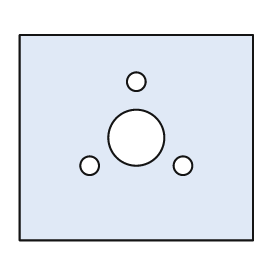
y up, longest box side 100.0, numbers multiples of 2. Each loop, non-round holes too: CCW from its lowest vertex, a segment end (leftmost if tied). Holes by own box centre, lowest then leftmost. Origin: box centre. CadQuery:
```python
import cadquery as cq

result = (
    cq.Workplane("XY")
    .moveTo(-50.0, -44.0)
    .lineTo(50.0, -44.0)
    .lineTo(50.0, 44.0)
    .lineTo(-50.0, 44.0)
    .close()
    .moveTo(-20.0, -12.0)
    .circle(4.0)
    .moveTo(20.0, -12.0)
    .circle(4.0)
    .moveTo(0.0, 0.0)
    .circle(12.0)
    .moveTo(0.0, 24.0)
    .circle(4.0)
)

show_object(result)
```